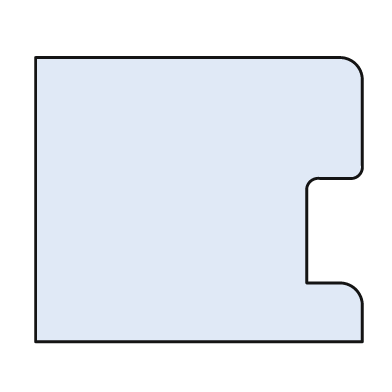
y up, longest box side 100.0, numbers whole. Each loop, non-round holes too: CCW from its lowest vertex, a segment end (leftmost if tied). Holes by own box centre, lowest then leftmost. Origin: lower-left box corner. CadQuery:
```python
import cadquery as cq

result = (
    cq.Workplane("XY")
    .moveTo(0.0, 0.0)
    .lineTo(100.0, 0.0)
    .lineTo(100.0, 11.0)
    .threePointArc((98.0, 16.0), (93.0, 18.0))
    .lineTo(83.0, 18.0)
    .lineTo(83.0, 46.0)
    .threePointArc((84.0, 49.0), (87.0, 50.0))
    .lineTo(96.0, 50.0)
    .threePointArc((99.0, 51.0), (100.0, 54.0))
    .lineTo(100.0, 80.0)
    .threePointArc((98.0, 85.0), (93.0, 87.0))
    .lineTo(0.0, 87.0)
    .close()
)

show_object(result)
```